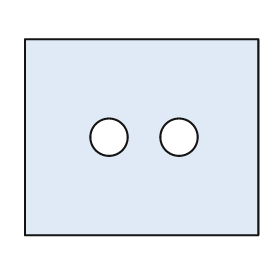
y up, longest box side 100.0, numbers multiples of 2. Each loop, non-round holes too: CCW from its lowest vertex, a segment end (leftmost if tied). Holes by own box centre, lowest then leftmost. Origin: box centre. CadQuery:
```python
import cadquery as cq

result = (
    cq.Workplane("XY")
    .moveTo(-50.0, -42.0)
    .lineTo(50.0, -42.0)
    .lineTo(50.0, 42.0)
    .lineTo(-50.0, 42.0)
    .close()
    .moveTo(-14.0, 0.0)
    .circle(8.0)
    .moveTo(16.0, 0.0)
    .circle(8.0)
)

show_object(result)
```